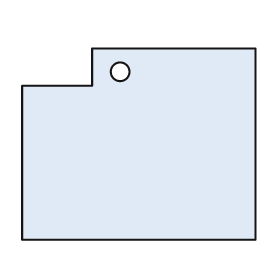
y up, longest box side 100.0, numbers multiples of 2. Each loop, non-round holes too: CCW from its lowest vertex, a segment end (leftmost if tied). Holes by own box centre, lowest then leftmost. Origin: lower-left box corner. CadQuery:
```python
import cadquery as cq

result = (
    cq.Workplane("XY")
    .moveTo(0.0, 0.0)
    .lineTo(100.0, 0.0)
    .lineTo(100.0, 82.0)
    .lineTo(30.0, 82.0)
    .lineTo(30.0, 66.0)
    .lineTo(0.0, 66.0)
    .close()
    .moveTo(42.0, 72.0)
    .circle(4.0)
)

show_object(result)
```